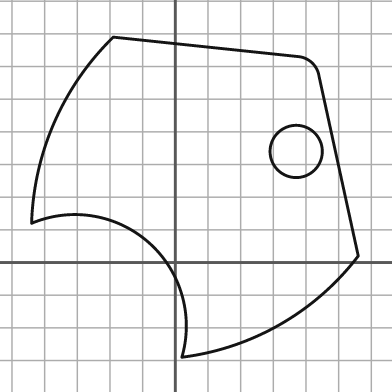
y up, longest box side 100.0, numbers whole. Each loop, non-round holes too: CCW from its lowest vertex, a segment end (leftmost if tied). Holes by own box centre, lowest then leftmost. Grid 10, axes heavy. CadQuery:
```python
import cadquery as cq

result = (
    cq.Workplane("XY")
    .moveTo(2.0, -29.0)
    .threePointArc((32.0, -19.0), (56.0, 2.0))
    .lineTo(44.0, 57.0)
    .threePointArc((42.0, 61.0), (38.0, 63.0))
    .lineTo(-19.0, 69.0)
    .threePointArc((-37.0, 43.0), (-44.0, 12.0))
    .threePointArc((-8.0, 6.0), (2.0, -29.0))
    .close()
    .moveTo(37.0, 34.0)
    .circle(8.0)
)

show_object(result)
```